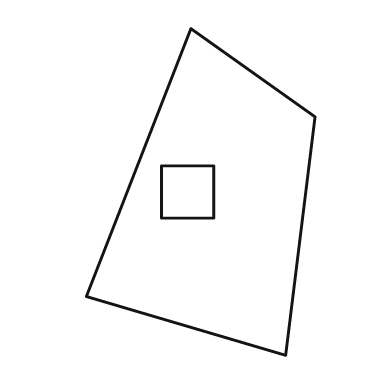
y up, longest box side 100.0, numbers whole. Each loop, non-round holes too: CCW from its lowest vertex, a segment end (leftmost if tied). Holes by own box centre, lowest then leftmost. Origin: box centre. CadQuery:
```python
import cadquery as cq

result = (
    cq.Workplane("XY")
    .moveTo(26.0, -50.0)
    .lineTo(35.0, 23.0)
    .lineTo(-3.0, 50.0)
    .lineTo(-35.0, -32.0)
    .close()
    .moveTo(-12.0, -8.0)
    .lineTo(4.0, -8.0)
    .lineTo(4.0, 8.0)
    .lineTo(-12.0, 8.0)
    .close()
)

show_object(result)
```